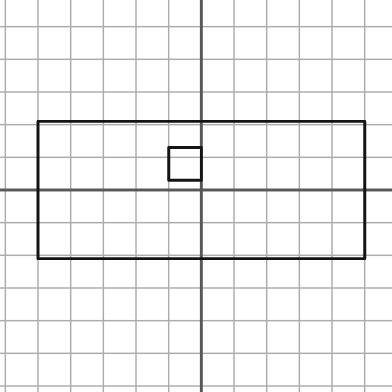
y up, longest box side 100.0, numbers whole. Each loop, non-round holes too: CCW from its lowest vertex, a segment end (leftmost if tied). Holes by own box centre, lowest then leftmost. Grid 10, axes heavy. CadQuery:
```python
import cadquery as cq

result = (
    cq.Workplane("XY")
    .moveTo(-50.0, -21.0)
    .lineTo(50.0, -21.0)
    .lineTo(50.0, 21.0)
    .lineTo(-50.0, 21.0)
    .close()
    .moveTo(-10.0, 3.0)
    .lineTo(0.0, 3.0)
    .lineTo(0.0, 13.0)
    .lineTo(-10.0, 13.0)
    .close()
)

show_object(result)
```